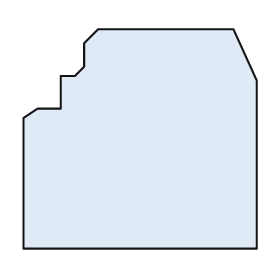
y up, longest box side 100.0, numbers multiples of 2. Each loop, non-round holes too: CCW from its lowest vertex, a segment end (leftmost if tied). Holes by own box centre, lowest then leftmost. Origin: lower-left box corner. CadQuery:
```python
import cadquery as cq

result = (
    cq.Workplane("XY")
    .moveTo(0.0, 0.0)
    .lineTo(100.0, 0.0)
    .lineTo(100.0, 72.0)
    .lineTo(90.0, 94.0)
    .lineTo(32.0, 94.0)
    .lineTo(26.0, 88.0)
    .lineTo(26.0, 78.0)
    .lineTo(22.0, 74.0)
    .lineTo(16.0, 74.0)
    .lineTo(16.0, 60.0)
    .lineTo(6.0, 60.0)
    .lineTo(0.0, 56.0)
    .close()
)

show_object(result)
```